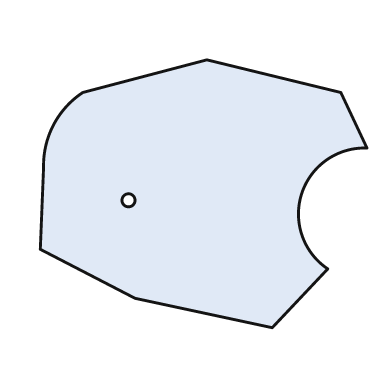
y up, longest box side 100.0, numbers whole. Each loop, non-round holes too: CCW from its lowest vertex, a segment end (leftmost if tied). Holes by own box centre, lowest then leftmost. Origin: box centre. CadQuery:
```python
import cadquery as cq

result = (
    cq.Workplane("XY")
    .moveTo(21.0, -41.0)
    .lineTo(38.0, -23.0)
    .threePointArc((30.0, 0.0), (50.0, 14.0))
    .lineTo(42.0, 31.0)
    .lineTo(1.0, 41.0)
    .lineTo(-37.0, 31.0)
    .threePointArc((-46.0, 21.0), (-49.0, 8.0))
    .lineTo(-50.0, -17.0)
    .lineTo(-21.0, -32.0)
    .close()
    .moveTo(-23.0, -2.0)
    .circle(2.0)
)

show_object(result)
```